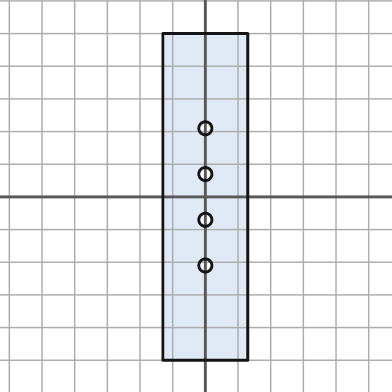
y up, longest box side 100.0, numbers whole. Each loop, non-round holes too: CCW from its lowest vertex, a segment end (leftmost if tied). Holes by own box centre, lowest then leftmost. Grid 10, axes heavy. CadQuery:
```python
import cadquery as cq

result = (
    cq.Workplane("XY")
    .moveTo(-13.0, -50.0)
    .lineTo(13.0, -50.0)
    .lineTo(13.0, 50.0)
    .lineTo(-13.0, 50.0)
    .close()
    .moveTo(0.0, -21.0)
    .circle(2.0)
    .moveTo(0.0, -7.0)
    .circle(2.0)
    .moveTo(0.0, 7.0)
    .circle(2.0)
    .moveTo(0.0, 21.0)
    .circle(2.0)
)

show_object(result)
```